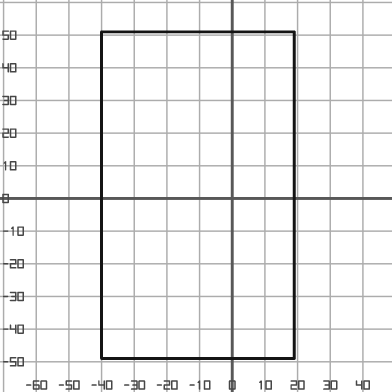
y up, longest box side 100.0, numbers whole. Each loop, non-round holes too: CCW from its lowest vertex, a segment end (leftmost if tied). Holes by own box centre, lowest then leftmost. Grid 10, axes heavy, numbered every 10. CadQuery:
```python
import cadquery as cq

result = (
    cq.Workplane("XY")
    .moveTo(-40.0, -49.0)
    .lineTo(19.0, -49.0)
    .lineTo(19.0, 51.0)
    .lineTo(-40.0, 51.0)
    .close()
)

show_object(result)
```